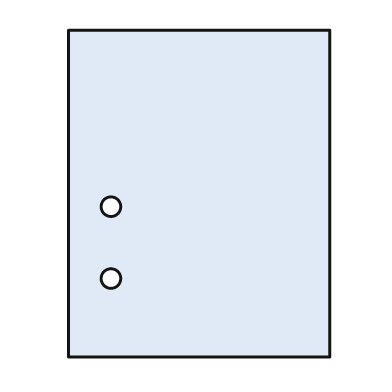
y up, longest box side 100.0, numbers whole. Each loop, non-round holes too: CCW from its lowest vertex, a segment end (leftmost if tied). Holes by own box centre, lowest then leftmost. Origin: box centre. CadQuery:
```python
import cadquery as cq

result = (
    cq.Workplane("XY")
    .moveTo(-40.0, -50.0)
    .lineTo(40.0, -50.0)
    .lineTo(40.0, 50.0)
    .lineTo(-40.0, 50.0)
    .close()
    .moveTo(-27.0, -26.0)
    .circle(3.0)
    .moveTo(-27.0, -4.0)
    .circle(3.0)
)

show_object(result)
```